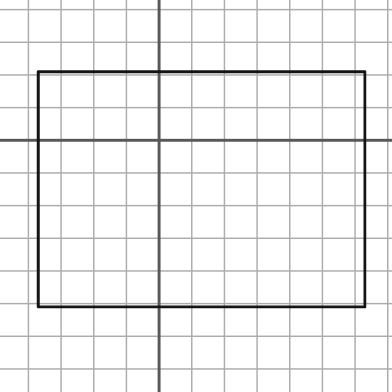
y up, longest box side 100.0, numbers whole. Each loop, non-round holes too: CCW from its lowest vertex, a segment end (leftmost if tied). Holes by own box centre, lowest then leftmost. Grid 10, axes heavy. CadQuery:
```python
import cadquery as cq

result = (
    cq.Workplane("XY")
    .moveTo(-37.0, -51.0)
    .lineTo(63.0, -51.0)
    .lineTo(63.0, 21.0)
    .lineTo(-37.0, 21.0)
    .close()
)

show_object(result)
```